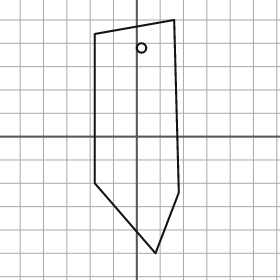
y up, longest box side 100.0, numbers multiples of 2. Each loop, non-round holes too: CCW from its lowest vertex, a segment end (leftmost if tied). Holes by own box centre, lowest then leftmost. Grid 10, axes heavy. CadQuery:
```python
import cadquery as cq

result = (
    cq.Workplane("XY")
    .moveTo(8.0, -50.0)
    .lineTo(18.0, -24.0)
    .lineTo(16.0, 50.0)
    .lineTo(-18.0, 44.0)
    .lineTo(-18.0, -20.0)
    .close()
    .moveTo(2.0, 38.0)
    .circle(2.0)
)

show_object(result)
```